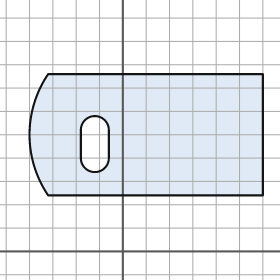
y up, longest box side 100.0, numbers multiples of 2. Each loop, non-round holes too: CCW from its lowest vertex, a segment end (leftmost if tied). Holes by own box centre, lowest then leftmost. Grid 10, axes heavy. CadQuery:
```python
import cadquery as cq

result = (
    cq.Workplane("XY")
    .moveTo(-32.0, 24.0)
    .lineTo(60.0, 24.0)
    .lineTo(60.0, 76.0)
    .lineTo(-32.0, 76.0)
    .threePointArc((-40.0, 50.0), (-32.0, 24.0))
    .close()
    .moveTo(-18.0, 40.0)
    .threePointArc((-12.0, 34.0), (-6.0, 40.0))
    .lineTo(-6.0, 52.0)
    .threePointArc((-12.0, 58.0), (-18.0, 52.0))
    .close()
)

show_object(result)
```